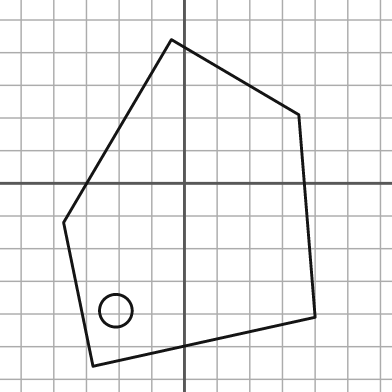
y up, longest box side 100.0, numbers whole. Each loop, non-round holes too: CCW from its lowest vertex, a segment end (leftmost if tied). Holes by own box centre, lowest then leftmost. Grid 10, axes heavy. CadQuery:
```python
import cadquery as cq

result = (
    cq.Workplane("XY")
    .moveTo(-28.0, -56.0)
    .lineTo(40.0, -41.0)
    .lineTo(35.0, 21.0)
    .lineTo(-4.0, 44.0)
    .lineTo(-37.0, -12.0)
    .close()
    .moveTo(-21.0, -39.0)
    .circle(5.0)
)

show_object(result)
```